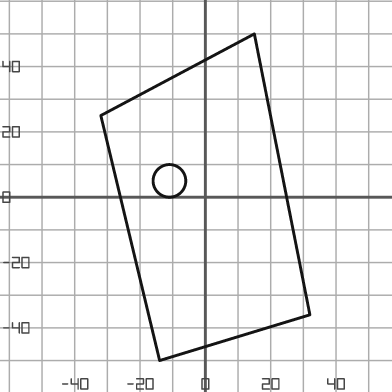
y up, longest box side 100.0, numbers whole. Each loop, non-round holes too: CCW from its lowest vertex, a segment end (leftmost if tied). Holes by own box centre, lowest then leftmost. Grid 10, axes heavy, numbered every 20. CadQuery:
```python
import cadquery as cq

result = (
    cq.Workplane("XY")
    .moveTo(-14.0, -50.0)
    .lineTo(32.0, -36.0)
    .lineTo(15.0, 50.0)
    .lineTo(-32.0, 25.0)
    .close()
    .moveTo(-11.0, 5.0)
    .circle(5.0)
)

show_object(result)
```